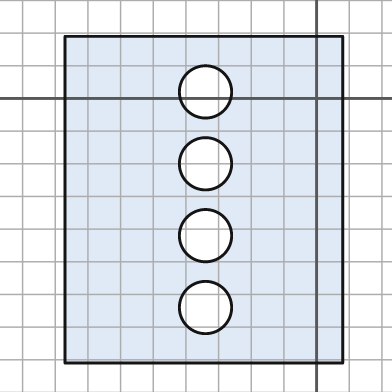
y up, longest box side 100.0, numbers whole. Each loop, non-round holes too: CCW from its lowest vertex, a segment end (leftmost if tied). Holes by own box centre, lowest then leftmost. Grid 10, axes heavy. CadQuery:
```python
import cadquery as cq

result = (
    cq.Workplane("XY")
    .moveTo(-77.0, -81.0)
    .lineTo(8.0, -81.0)
    .lineTo(8.0, 19.0)
    .lineTo(-77.0, 19.0)
    .close()
    .moveTo(-34.0, -64.0)
    .circle(8.0)
    .moveTo(-34.0, -42.0)
    .circle(8.0)
    .moveTo(-34.0, -20.0)
    .circle(8.0)
    .moveTo(-34.0, 2.0)
    .circle(8.0)
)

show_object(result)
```